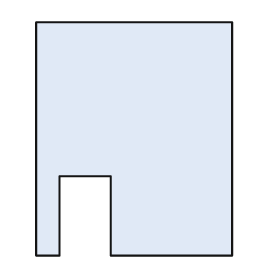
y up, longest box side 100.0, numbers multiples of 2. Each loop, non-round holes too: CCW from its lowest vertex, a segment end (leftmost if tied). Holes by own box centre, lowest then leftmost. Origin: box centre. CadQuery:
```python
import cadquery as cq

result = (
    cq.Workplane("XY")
    .moveTo(-42.0, -50.0)
    .lineTo(-32.0, -50.0)
    .lineTo(-32.0, -16.0)
    .lineTo(-10.0, -16.0)
    .lineTo(-10.0, -50.0)
    .lineTo(42.0, -50.0)
    .lineTo(42.0, 50.0)
    .lineTo(-42.0, 50.0)
    .close()
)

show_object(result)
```